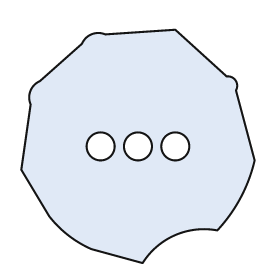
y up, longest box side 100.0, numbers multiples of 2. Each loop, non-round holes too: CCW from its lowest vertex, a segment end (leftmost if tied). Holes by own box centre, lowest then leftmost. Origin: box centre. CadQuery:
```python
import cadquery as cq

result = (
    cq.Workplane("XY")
    .moveTo(2.0, -50.0)
    .threePointArc((16.0, -38.0), (34.0, -36.0))
    .threePointArc((44.0, -22.0), (50.0, -6.0))
    .lineTo(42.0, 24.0)
    .threePointArc((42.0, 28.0), (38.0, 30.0))
    .lineTo(16.0, 50.0)
    .lineTo(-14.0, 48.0)
    .threePointArc((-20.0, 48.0), (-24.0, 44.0))
    .lineTo(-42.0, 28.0)
    .threePointArc((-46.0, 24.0), (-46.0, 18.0))
    .lineTo(-50.0, -10.0)
    .lineTo(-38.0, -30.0)
    .threePointArc((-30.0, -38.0), (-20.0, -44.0))
    .close()
    .moveTo(-16.0, 0.0)
    .circle(6.0)
    .moveTo(0.0, 0.0)
    .circle(6.0)
    .moveTo(16.0, 0.0)
    .circle(6.0)
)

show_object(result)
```